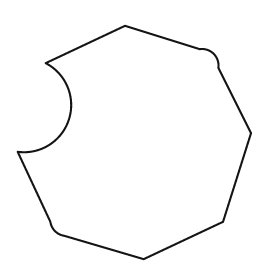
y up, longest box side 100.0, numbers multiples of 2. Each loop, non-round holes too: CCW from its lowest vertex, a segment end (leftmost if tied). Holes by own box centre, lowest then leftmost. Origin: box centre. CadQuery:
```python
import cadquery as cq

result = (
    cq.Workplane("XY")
    .moveTo(4.0, -50.0)
    .lineTo(38.0, -34.0)
    .lineTo(50.0, 4.0)
    .lineTo(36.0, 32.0)
    .threePointArc((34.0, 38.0), (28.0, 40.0))
    .lineTo(-4.0, 50.0)
    .lineTo(-38.0, 34.0)
    .threePointArc((-28.0, 10.0), (-50.0, -4.0))
    .lineTo(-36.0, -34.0)
    .threePointArc((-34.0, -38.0), (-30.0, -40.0))
    .close()
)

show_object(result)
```